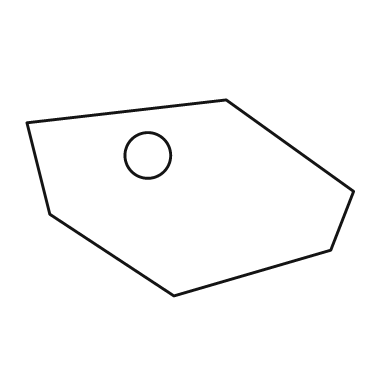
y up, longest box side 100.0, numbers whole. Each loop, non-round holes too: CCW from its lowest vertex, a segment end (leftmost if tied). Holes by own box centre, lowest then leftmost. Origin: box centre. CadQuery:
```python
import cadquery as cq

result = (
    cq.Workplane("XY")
    .moveTo(-5.0, -30.0)
    .lineTo(43.0, -16.0)
    .lineTo(50.0, 2.0)
    .lineTo(11.0, 30.0)
    .lineTo(-50.0, 23.0)
    .lineTo(-43.0, -5.0)
    .close()
    .moveTo(-13.0, 13.0)
    .circle(7.0)
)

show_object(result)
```